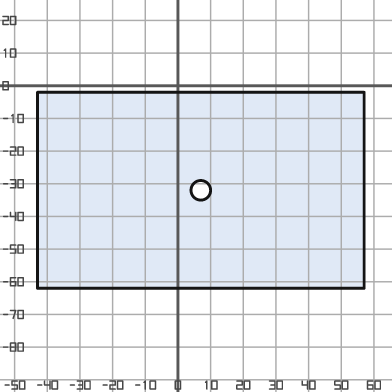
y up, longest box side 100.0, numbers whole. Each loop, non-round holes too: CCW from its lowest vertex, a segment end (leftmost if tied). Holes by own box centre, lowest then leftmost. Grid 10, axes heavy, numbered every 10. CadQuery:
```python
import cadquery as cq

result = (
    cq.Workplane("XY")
    .moveTo(-43.0, -62.0)
    .lineTo(57.0, -62.0)
    .lineTo(57.0, -2.0)
    .lineTo(-43.0, -2.0)
    .close()
    .moveTo(7.0, -32.0)
    .circle(3.0)
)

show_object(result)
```